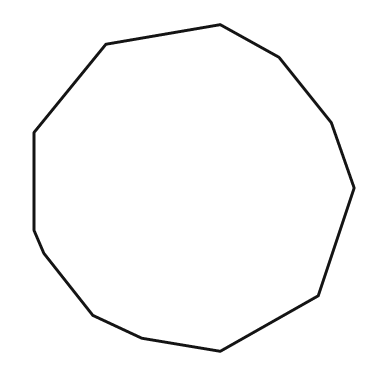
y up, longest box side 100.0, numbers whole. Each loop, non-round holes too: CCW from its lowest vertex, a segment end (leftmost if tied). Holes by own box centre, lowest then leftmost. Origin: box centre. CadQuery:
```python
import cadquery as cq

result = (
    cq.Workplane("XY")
    .moveTo(8.0, -50.0)
    .lineTo(38.0, -33.0)
    .lineTo(49.0, 0.0)
    .lineTo(42.0, 20.0)
    .lineTo(26.0, 40.0)
    .lineTo(8.0, 50.0)
    .lineTo(-27.0, 44.0)
    .lineTo(-49.0, 17.0)
    .lineTo(-49.0, -13.0)
    .lineTo(-46.0, -20.0)
    .lineTo(-31.0, -39.0)
    .lineTo(-16.0, -46.0)
    .close()
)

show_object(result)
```